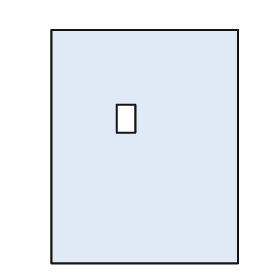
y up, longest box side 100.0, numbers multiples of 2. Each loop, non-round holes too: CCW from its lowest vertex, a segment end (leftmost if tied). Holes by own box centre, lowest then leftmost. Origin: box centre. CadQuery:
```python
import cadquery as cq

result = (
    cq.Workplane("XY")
    .moveTo(-40.0, -50.0)
    .lineTo(40.0, -50.0)
    .lineTo(40.0, 50.0)
    .lineTo(-40.0, 50.0)
    .close()
    .moveTo(-12.0, 6.0)
    .lineTo(-4.0, 6.0)
    .lineTo(-4.0, 18.0)
    .lineTo(-12.0, 18.0)
    .close()
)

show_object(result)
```